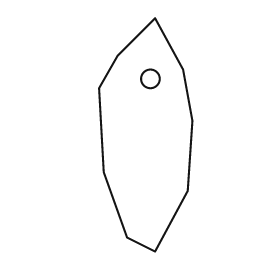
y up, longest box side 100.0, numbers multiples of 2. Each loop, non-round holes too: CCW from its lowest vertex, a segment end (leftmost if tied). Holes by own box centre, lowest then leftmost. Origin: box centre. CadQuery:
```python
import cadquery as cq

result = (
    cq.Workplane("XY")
    .moveTo(4.0, -50.0)
    .lineTo(18.0, -24.0)
    .lineTo(20.0, 6.0)
    .lineTo(16.0, 28.0)
    .lineTo(4.0, 50.0)
    .lineTo(-12.0, 34.0)
    .lineTo(-20.0, 20.0)
    .lineTo(-18.0, -16.0)
    .lineTo(-8.0, -44.0)
    .close()
    .moveTo(2.0, 24.0)
    .circle(4.0)
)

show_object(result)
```